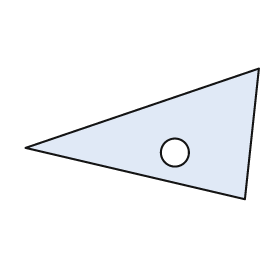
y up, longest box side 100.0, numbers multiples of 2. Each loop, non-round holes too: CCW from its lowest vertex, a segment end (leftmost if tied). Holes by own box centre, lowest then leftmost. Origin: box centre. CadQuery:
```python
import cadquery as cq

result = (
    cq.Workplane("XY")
    .moveTo(44.0, -28.0)
    .lineTo(50.0, 28.0)
    .lineTo(-50.0, -6.0)
    .close()
    .moveTo(14.0, -8.0)
    .circle(6.0)
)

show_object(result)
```